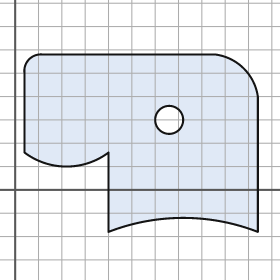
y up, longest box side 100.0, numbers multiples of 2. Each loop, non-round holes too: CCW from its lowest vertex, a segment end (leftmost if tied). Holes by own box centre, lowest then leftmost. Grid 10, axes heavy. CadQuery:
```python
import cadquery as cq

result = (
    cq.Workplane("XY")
    .moveTo(40.0, -18.0)
    .threePointArc((72.0, -12.0), (104.0, -18.0))
    .lineTo(104.0, 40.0)
    .threePointArc((98.0, 52.0), (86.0, 58.0))
    .lineTo(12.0, 58.0)
    .threePointArc((6.0, 56.0), (4.0, 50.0))
    .lineTo(4.0, 16.0)
    .threePointArc((22.0, 10.0), (40.0, 16.0))
    .close()
    .moveTo(66.0, 30.0)
    .circle(6.0)
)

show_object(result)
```